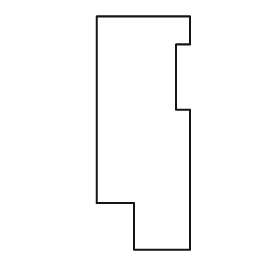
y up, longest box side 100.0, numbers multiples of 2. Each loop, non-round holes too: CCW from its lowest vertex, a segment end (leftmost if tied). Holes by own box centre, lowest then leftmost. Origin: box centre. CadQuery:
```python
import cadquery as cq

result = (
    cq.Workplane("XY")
    .moveTo(-4.0, -50.0)
    .lineTo(20.0, -50.0)
    .lineTo(20.0, 10.0)
    .lineTo(14.0, 10.0)
    .lineTo(14.0, 38.0)
    .lineTo(20.0, 38.0)
    .lineTo(20.0, 50.0)
    .lineTo(-20.0, 50.0)
    .lineTo(-20.0, -30.0)
    .lineTo(-4.0, -30.0)
    .close()
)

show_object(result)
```